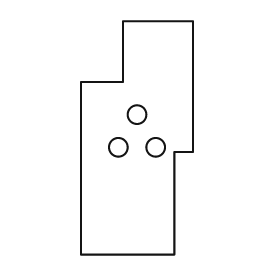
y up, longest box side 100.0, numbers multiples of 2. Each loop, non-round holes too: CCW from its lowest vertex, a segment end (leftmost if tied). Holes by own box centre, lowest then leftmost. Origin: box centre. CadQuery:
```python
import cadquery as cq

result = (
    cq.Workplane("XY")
    .moveTo(-24.0, -50.0)
    .lineTo(16.0, -50.0)
    .lineTo(16.0, -6.0)
    .lineTo(24.0, -6.0)
    .lineTo(24.0, 50.0)
    .lineTo(-6.0, 50.0)
    .lineTo(-6.0, 24.0)
    .lineTo(-24.0, 24.0)
    .close()
    .moveTo(-8.0, -4.0)
    .circle(4.0)
    .moveTo(8.0, -4.0)
    .circle(4.0)
    .moveTo(0.0, 10.0)
    .circle(4.0)
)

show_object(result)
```